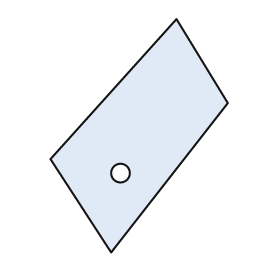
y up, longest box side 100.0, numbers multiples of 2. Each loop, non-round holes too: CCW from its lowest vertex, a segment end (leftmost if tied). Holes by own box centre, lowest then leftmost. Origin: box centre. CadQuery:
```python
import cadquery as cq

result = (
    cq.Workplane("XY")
    .moveTo(-12.0, -50.0)
    .lineTo(38.0, 14.0)
    .lineTo(16.0, 50.0)
    .lineTo(-38.0, -10.0)
    .close()
    .moveTo(-8.0, -16.0)
    .circle(4.0)
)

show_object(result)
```